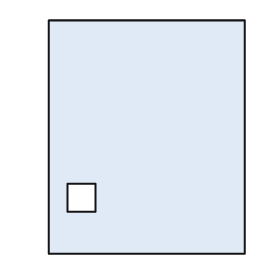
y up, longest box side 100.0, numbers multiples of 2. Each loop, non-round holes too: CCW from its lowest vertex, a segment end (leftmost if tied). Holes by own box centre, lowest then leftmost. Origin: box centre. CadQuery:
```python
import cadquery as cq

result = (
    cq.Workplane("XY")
    .moveTo(-42.0, -50.0)
    .lineTo(42.0, -50.0)
    .lineTo(42.0, 50.0)
    .lineTo(-42.0, 50.0)
    .close()
    .moveTo(-34.0, -32.0)
    .lineTo(-22.0, -32.0)
    .lineTo(-22.0, -20.0)
    .lineTo(-34.0, -20.0)
    .close()
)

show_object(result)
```